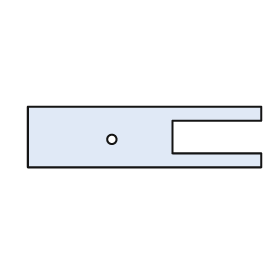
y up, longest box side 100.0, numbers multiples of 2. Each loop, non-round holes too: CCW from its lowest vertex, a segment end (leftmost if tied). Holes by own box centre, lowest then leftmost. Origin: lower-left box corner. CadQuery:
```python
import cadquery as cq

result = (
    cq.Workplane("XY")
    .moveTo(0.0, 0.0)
    .lineTo(100.0, 0.0)
    .lineTo(100.0, 6.0)
    .lineTo(62.0, 6.0)
    .lineTo(62.0, 20.0)
    .lineTo(100.0, 20.0)
    .lineTo(100.0, 26.0)
    .lineTo(0.0, 26.0)
    .close()
    .moveTo(36.0, 12.0)
    .circle(2.0)
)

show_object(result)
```